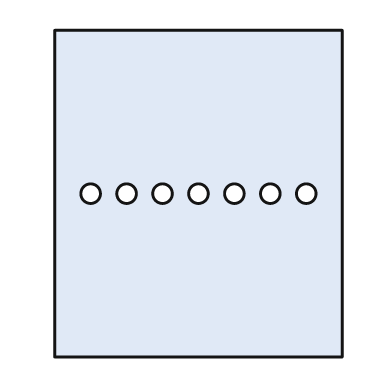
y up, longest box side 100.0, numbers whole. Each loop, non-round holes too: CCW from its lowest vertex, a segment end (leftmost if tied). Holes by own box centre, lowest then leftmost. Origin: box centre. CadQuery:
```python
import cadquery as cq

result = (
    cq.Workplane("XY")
    .moveTo(-44.0, -50.0)
    .lineTo(44.0, -50.0)
    .lineTo(44.0, 50.0)
    .lineTo(-44.0, 50.0)
    .close()
    .moveTo(-33.0, 0.0)
    .circle(3.0)
    .moveTo(-22.0, 0.0)
    .circle(3.0)
    .moveTo(-11.0, 0.0)
    .circle(3.0)
    .moveTo(0.0, 0.0)
    .circle(3.0)
    .moveTo(11.0, 0.0)
    .circle(3.0)
    .moveTo(22.0, 0.0)
    .circle(3.0)
    .moveTo(33.0, 0.0)
    .circle(3.0)
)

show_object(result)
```